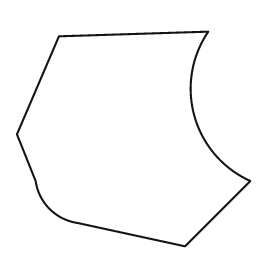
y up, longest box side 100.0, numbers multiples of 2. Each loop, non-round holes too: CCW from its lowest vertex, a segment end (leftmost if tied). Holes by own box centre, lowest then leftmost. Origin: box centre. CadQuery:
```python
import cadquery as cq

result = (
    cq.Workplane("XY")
    .moveTo(22.0, -46.0)
    .lineTo(50.0, -18.0)
    .threePointArc((26.0, 10.0), (32.0, 46.0))
    .lineTo(-32.0, 44.0)
    .lineTo(-50.0, 2.0)
    .lineTo(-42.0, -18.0)
    .threePointArc((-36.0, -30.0), (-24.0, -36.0))
    .close()
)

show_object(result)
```